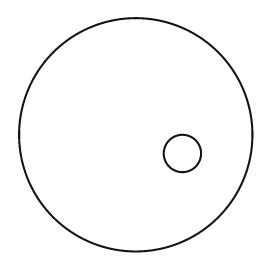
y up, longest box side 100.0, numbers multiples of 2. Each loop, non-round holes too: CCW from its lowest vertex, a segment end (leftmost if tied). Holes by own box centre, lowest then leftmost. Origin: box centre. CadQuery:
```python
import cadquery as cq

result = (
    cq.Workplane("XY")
    .moveTo(0.0, 0.0)
    .circle(50.0)
    .moveTo(20.0, -8.0)
    .circle(8.0)
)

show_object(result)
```